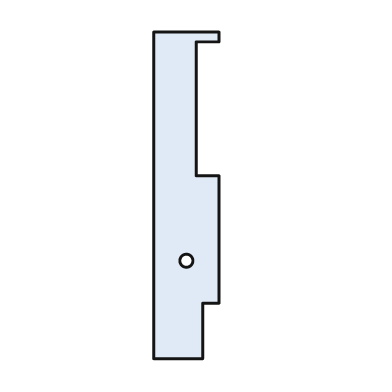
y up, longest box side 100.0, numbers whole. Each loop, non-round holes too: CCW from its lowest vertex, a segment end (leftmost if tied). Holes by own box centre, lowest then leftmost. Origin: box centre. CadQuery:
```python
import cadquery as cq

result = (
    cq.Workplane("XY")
    .moveTo(-10.0, -50.0)
    .lineTo(5.0, -50.0)
    .lineTo(5.0, -33.0)
    .lineTo(10.0, -33.0)
    .lineTo(10.0, 6.0)
    .lineTo(3.0, 6.0)
    .lineTo(3.0, 47.0)
    .lineTo(10.0, 47.0)
    .lineTo(10.0, 50.0)
    .lineTo(-10.0, 50.0)
    .close()
    .moveTo(0.0, -20.0)
    .circle(2.0)
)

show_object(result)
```